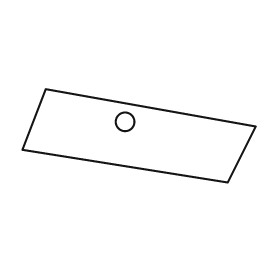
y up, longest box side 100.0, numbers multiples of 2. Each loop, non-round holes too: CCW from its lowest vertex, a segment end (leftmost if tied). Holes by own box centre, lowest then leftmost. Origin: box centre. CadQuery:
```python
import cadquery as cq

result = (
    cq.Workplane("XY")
    .moveTo(38.0, -20.0)
    .lineTo(50.0, 4.0)
    .lineTo(-40.0, 20.0)
    .lineTo(-50.0, -6.0)
    .close()
    .moveTo(-6.0, 6.0)
    .circle(4.0)
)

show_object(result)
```